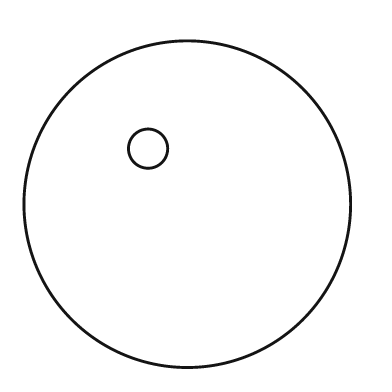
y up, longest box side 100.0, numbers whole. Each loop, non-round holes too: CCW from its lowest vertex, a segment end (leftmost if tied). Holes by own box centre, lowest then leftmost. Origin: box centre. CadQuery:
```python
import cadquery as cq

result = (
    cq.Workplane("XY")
    .moveTo(0.0, 0.0)
    .circle(50.0)
    .moveTo(-12.0, 17.0)
    .circle(6.0)
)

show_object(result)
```